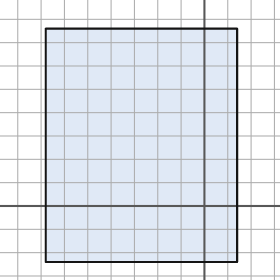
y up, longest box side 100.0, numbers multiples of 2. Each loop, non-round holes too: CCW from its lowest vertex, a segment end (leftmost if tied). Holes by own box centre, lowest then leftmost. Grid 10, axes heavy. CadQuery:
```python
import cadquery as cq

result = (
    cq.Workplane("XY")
    .moveTo(-68.0, -24.0)
    .lineTo(14.0, -24.0)
    .lineTo(14.0, 76.0)
    .lineTo(-68.0, 76.0)
    .close()
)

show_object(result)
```